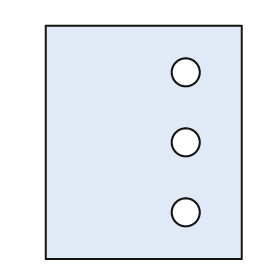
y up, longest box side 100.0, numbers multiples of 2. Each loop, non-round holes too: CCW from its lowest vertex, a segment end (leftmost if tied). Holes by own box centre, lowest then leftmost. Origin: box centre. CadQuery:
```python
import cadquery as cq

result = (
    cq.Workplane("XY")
    .moveTo(-42.0, -50.0)
    .lineTo(42.0, -50.0)
    .lineTo(42.0, 50.0)
    .lineTo(-42.0, 50.0)
    .close()
    .moveTo(18.0, -30.0)
    .circle(6.0)
    .moveTo(18.0, 0.0)
    .circle(6.0)
    .moveTo(18.0, 30.0)
    .circle(6.0)
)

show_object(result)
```